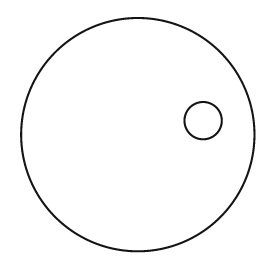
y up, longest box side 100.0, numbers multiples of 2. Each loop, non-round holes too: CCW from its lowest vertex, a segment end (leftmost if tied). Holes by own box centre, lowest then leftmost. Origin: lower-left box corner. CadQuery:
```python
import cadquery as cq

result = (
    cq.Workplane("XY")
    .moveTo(50.0, 50.0)
    .circle(50.0)
    .moveTo(78.0, 56.0)
    .circle(8.0)
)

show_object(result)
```